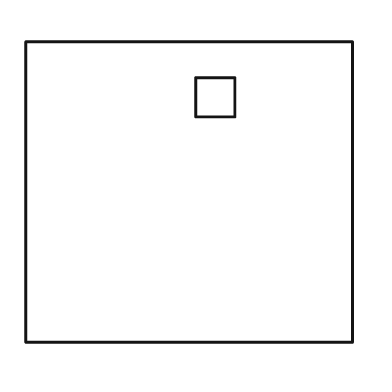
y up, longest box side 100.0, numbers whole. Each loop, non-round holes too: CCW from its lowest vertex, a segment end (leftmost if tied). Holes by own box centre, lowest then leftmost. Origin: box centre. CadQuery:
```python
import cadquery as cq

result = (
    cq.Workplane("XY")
    .moveTo(-50.0, -46.0)
    .lineTo(50.0, -46.0)
    .lineTo(50.0, 46.0)
    .lineTo(-50.0, 46.0)
    .close()
    .moveTo(2.0, 23.0)
    .lineTo(14.0, 23.0)
    .lineTo(14.0, 35.0)
    .lineTo(2.0, 35.0)
    .close()
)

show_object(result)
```